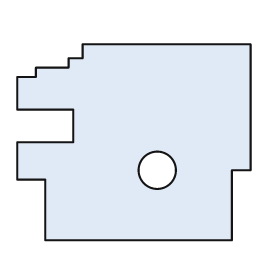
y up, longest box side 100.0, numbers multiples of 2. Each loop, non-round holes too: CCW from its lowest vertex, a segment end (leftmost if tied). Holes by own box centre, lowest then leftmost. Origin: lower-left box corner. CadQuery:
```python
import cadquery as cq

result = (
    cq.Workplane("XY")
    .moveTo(12.0, 0.0)
    .lineTo(92.0, 0.0)
    .lineTo(92.0, 30.0)
    .lineTo(100.0, 30.0)
    .lineTo(100.0, 84.0)
    .lineTo(28.0, 84.0)
    .lineTo(28.0, 78.0)
    .lineTo(22.0, 78.0)
    .lineTo(22.0, 74.0)
    .lineTo(8.0, 74.0)
    .lineTo(8.0, 70.0)
    .lineTo(0.0, 70.0)
    .lineTo(0.0, 56.0)
    .lineTo(24.0, 56.0)
    .lineTo(24.0, 42.0)
    .lineTo(0.0, 42.0)
    .lineTo(0.0, 26.0)
    .lineTo(12.0, 26.0)
    .close()
    .moveTo(60.0, 30.0)
    .circle(8.0)
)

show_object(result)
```